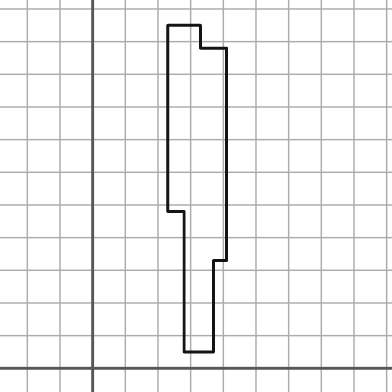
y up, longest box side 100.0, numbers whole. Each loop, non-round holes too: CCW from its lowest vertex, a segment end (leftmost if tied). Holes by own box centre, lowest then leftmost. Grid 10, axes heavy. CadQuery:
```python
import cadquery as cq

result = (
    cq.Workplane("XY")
    .moveTo(28.0, 5.0)
    .lineTo(37.0, 5.0)
    .lineTo(37.0, 33.0)
    .lineTo(41.0, 33.0)
    .lineTo(41.0, 98.0)
    .lineTo(33.0, 98.0)
    .lineTo(33.0, 105.0)
    .lineTo(23.0, 105.0)
    .lineTo(23.0, 48.0)
    .lineTo(28.0, 48.0)
    .close()
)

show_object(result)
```